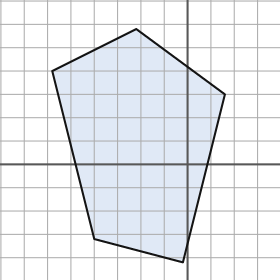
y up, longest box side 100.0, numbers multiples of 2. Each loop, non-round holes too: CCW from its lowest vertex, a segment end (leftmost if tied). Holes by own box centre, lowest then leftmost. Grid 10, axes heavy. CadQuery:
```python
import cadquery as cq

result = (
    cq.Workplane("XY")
    .moveTo(-2.0, -42.0)
    .lineTo(16.0, 30.0)
    .lineTo(-22.0, 58.0)
    .lineTo(-58.0, 40.0)
    .lineTo(-40.0, -32.0)
    .close()
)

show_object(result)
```